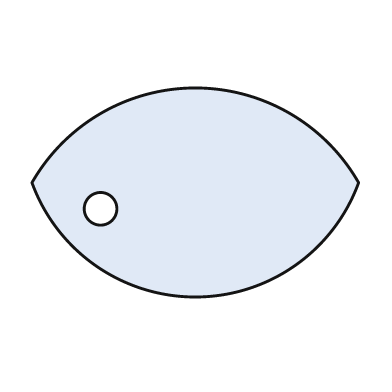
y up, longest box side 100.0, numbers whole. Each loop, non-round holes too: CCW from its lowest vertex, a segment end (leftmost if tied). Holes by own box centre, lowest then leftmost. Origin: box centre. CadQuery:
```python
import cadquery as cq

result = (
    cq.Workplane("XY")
    .moveTo(-50.0, 3.0)
    .threePointArc((0.0, -32.0), (50.0, 3.0))
    .threePointArc((0.0, 32.0), (-50.0, 3.0))
    .close()
    .moveTo(-29.0, -5.0)
    .circle(5.0)
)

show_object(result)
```